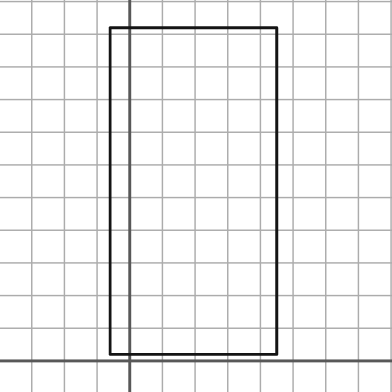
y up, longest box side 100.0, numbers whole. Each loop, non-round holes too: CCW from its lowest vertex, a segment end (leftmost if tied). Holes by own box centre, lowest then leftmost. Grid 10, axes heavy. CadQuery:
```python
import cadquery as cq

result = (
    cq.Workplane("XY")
    .moveTo(-6.0, 2.0)
    .lineTo(45.0, 2.0)
    .lineTo(45.0, 102.0)
    .lineTo(-6.0, 102.0)
    .close()
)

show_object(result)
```